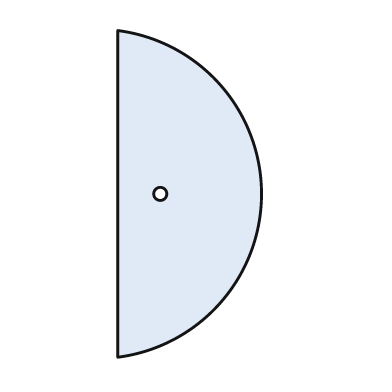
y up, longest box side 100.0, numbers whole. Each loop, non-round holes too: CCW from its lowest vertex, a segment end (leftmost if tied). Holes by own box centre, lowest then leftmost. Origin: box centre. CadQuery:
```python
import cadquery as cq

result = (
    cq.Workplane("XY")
    .moveTo(-22.0, -50.0)
    .threePointArc((22.0, 0.0), (-22.0, 50.0))
    .close()
    .moveTo(-9.0, 0.0)
    .circle(2.0)
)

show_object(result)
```